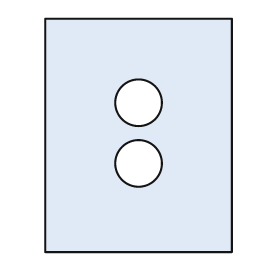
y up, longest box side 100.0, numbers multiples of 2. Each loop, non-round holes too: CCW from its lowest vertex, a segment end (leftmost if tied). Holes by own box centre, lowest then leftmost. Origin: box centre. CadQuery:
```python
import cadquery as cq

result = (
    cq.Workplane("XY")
    .moveTo(-40.0, -50.0)
    .lineTo(40.0, -50.0)
    .lineTo(40.0, 50.0)
    .lineTo(-40.0, 50.0)
    .close()
    .moveTo(0.0, -12.0)
    .circle(10.0)
    .moveTo(0.0, 14.0)
    .circle(10.0)
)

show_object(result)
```